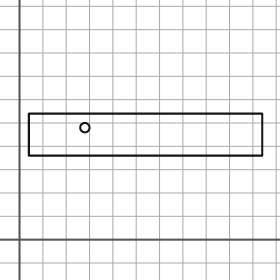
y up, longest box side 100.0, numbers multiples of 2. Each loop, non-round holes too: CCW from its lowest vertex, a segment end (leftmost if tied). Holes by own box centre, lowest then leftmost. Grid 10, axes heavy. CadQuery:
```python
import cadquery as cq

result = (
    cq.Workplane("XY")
    .moveTo(4.0, 36.0)
    .lineTo(104.0, 36.0)
    .lineTo(104.0, 54.0)
    .lineTo(4.0, 54.0)
    .close()
    .moveTo(28.0, 48.0)
    .circle(2.0)
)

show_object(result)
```